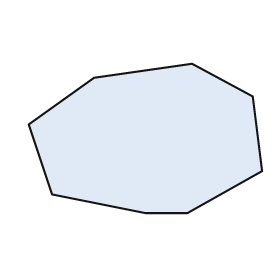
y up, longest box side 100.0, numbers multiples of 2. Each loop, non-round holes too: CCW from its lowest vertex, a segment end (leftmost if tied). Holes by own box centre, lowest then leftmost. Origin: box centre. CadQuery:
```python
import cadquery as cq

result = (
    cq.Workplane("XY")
    .moveTo(0.0, -32.0)
    .lineTo(18.0, -32.0)
    .lineTo(50.0, -14.0)
    .lineTo(46.0, 18.0)
    .lineTo(20.0, 32.0)
    .lineTo(-22.0, 26.0)
    .lineTo(-50.0, 6.0)
    .lineTo(-40.0, -24.0)
    .close()
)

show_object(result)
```